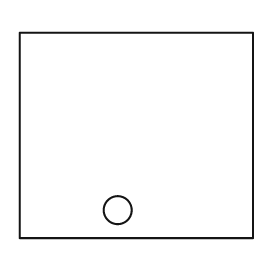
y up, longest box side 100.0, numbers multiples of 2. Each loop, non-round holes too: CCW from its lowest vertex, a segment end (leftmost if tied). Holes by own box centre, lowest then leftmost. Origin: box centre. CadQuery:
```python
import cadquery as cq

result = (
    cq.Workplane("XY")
    .moveTo(-50.0, -44.0)
    .lineTo(50.0, -44.0)
    .lineTo(50.0, 44.0)
    .lineTo(-50.0, 44.0)
    .close()
    .moveTo(-8.0, -32.0)
    .circle(6.0)
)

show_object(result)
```